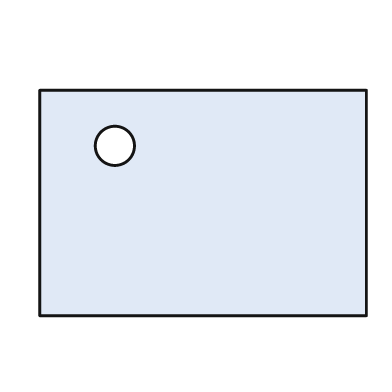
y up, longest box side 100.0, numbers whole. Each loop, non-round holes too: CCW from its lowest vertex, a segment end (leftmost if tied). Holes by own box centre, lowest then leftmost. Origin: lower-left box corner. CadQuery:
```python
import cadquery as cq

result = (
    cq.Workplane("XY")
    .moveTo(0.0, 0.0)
    .lineTo(100.0, 0.0)
    .lineTo(100.0, 69.0)
    .lineTo(0.0, 69.0)
    .close()
    .moveTo(23.0, 52.0)
    .circle(6.0)
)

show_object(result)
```